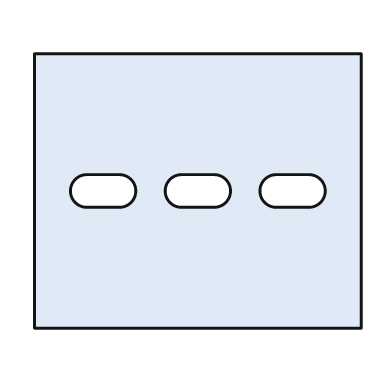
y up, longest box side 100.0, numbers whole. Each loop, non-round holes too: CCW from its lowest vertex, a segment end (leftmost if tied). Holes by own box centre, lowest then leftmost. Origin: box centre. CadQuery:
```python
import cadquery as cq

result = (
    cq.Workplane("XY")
    .moveTo(-50.0, -42.0)
    .lineTo(50.0, -42.0)
    .lineTo(50.0, 42.0)
    .lineTo(-50.0, 42.0)
    .close()
    .moveTo(-34.0, -5.0)
    .lineTo(-24.0, -5.0)
    .threePointArc((-19.0, 0.0), (-24.0, 5.0))
    .lineTo(-34.0, 5.0)
    .threePointArc((-39.0, 0.0), (-34.0, -5.0))
    .close()
    .moveTo(-5.0, -5.0)
    .lineTo(5.0, -5.0)
    .threePointArc((10.0, 0.0), (5.0, 5.0))
    .lineTo(-5.0, 5.0)
    .threePointArc((-10.0, 0.0), (-5.0, -5.0))
    .close()
    .moveTo(24.0, -5.0)
    .lineTo(34.0, -5.0)
    .threePointArc((39.0, 0.0), (34.0, 5.0))
    .lineTo(24.0, 5.0)
    .threePointArc((19.0, 0.0), (24.0, -5.0))
    .close()
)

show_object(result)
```